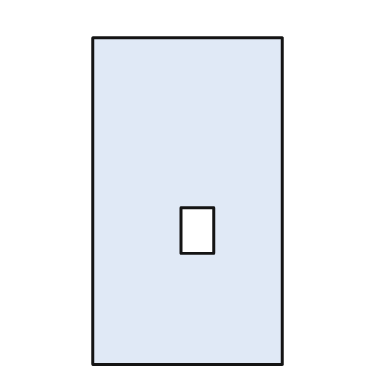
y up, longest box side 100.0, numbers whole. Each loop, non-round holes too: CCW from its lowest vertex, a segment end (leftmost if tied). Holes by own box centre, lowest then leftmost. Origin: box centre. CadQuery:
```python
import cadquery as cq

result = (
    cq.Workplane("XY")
    .moveTo(-29.0, -50.0)
    .lineTo(29.0, -50.0)
    .lineTo(29.0, 50.0)
    .lineTo(-29.0, 50.0)
    .close()
    .moveTo(-2.0, -16.0)
    .lineTo(8.0, -16.0)
    .lineTo(8.0, -2.0)
    .lineTo(-2.0, -2.0)
    .close()
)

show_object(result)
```